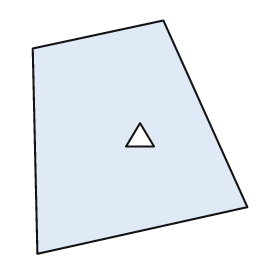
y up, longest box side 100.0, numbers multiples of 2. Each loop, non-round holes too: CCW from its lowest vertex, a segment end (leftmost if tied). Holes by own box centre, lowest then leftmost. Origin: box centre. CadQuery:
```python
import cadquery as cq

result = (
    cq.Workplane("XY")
    .moveTo(-44.0, -50.0)
    .lineTo(46.0, -30.0)
    .lineTo(10.0, 50.0)
    .lineTo(-46.0, 38.0)
    .close()
    .moveTo(-6.0, -4.0)
    .lineTo(6.0, -4.0)
    .lineTo(0.0, 6.0)
    .close()
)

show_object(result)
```